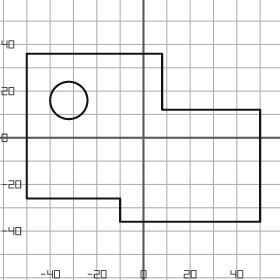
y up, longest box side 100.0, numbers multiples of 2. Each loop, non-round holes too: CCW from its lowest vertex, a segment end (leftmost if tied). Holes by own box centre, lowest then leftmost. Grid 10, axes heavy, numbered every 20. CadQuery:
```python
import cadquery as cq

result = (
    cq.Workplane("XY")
    .moveTo(-10.0, -36.0)
    .lineTo(50.0, -36.0)
    .lineTo(50.0, 12.0)
    .lineTo(8.0, 12.0)
    .lineTo(8.0, 36.0)
    .lineTo(-50.0, 36.0)
    .lineTo(-50.0, -26.0)
    .lineTo(-10.0, -26.0)
    .close()
    .moveTo(-32.0, 16.0)
    .circle(8.0)
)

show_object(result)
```